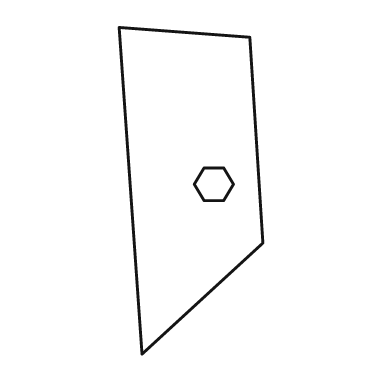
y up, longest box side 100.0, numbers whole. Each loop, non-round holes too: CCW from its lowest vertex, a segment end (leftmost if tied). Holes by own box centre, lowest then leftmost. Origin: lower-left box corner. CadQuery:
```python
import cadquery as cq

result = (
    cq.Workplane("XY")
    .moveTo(7.0, 0.0)
    .lineTo(44.0, 34.0)
    .lineTo(40.0, 97.0)
    .lineTo(0.0, 100.0)
    .close()
    .moveTo(26.0, 47.0)
    .lineTo(32.0, 47.0)
    .lineTo(35.0, 52.0)
    .lineTo(32.0, 57.0)
    .lineTo(26.0, 57.0)
    .lineTo(23.0, 52.0)
    .close()
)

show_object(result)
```